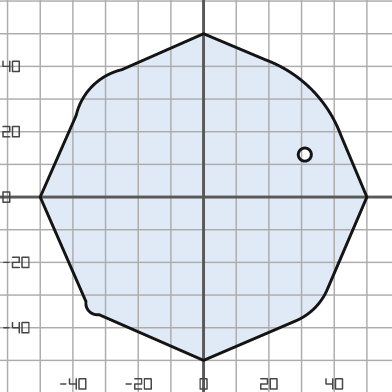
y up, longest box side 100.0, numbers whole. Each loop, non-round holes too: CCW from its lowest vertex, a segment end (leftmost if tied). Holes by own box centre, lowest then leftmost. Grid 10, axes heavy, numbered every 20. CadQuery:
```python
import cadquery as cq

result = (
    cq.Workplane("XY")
    .moveTo(0.0, -50.0)
    .lineTo(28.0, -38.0)
    .threePointArc((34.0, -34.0), (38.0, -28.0))
    .lineTo(50.0, 0.0)
    .lineTo(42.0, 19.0)
    .threePointArc((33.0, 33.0), (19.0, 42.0))
    .lineTo(0.0, 50.0)
    .lineTo(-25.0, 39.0)
    .threePointArc((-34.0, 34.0), (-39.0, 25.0))
    .lineTo(-50.0, 0.0)
    .lineTo(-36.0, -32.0)
    .threePointArc((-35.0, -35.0), (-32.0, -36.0))
    .close()
    .moveTo(31.0, 13.0)
    .circle(2.0)
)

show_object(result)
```